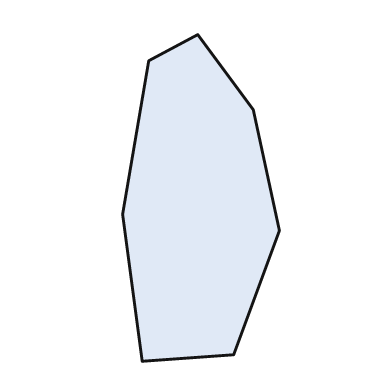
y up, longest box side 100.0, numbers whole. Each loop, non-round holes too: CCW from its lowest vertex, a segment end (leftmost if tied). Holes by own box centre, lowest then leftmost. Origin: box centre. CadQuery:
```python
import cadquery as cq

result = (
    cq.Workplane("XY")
    .moveTo(-18.0, -50.0)
    .lineTo(10.0, -48.0)
    .lineTo(24.0, -10.0)
    .lineTo(16.0, 27.0)
    .lineTo(-1.0, 50.0)
    .lineTo(-16.0, 42.0)
    .lineTo(-24.0, -5.0)
    .close()
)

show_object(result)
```